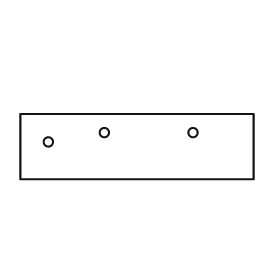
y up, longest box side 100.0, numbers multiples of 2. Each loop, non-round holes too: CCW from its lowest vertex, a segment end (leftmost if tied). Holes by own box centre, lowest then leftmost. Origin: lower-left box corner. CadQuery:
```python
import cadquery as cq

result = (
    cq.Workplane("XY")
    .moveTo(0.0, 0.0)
    .lineTo(100.0, 0.0)
    .lineTo(100.0, 28.0)
    .lineTo(0.0, 28.0)
    .close()
    .moveTo(12.0, 16.0)
    .circle(2.0)
    .moveTo(36.0, 20.0)
    .circle(2.0)
    .moveTo(74.0, 20.0)
    .circle(2.0)
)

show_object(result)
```